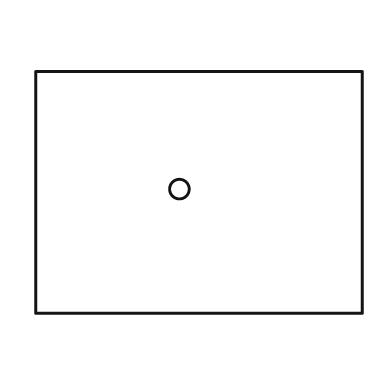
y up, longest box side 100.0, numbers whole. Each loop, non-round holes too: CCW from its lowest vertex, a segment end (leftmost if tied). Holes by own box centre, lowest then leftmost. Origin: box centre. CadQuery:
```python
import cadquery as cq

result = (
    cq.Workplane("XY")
    .moveTo(-50.0, -37.0)
    .lineTo(50.0, -37.0)
    .lineTo(50.0, 37.0)
    .lineTo(-50.0, 37.0)
    .close()
    .moveTo(-6.0, 1.0)
    .circle(3.0)
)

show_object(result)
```